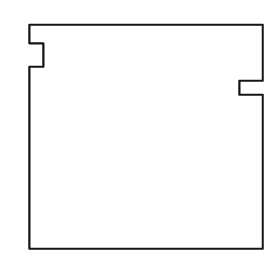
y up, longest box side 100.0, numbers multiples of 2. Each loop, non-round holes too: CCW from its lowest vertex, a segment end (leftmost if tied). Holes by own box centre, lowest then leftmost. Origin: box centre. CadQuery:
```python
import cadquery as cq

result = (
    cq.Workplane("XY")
    .moveTo(-50.0, -48.0)
    .lineTo(50.0, -48.0)
    .lineTo(50.0, 18.0)
    .lineTo(40.0, 18.0)
    .lineTo(40.0, 24.0)
    .lineTo(50.0, 24.0)
    .lineTo(50.0, 48.0)
    .lineTo(-50.0, 48.0)
    .lineTo(-50.0, 40.0)
    .lineTo(-44.0, 40.0)
    .lineTo(-44.0, 30.0)
    .lineTo(-50.0, 30.0)
    .close()
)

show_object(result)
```